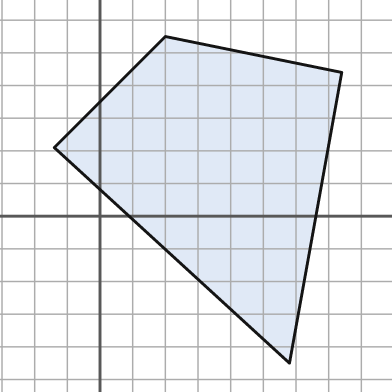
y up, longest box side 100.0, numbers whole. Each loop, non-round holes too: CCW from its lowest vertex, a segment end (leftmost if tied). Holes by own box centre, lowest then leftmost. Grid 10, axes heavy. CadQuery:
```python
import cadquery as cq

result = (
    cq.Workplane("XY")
    .moveTo(58.0, -45.0)
    .lineTo(74.0, 44.0)
    .lineTo(20.0, 55.0)
    .lineTo(-14.0, 21.0)
    .close()
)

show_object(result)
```